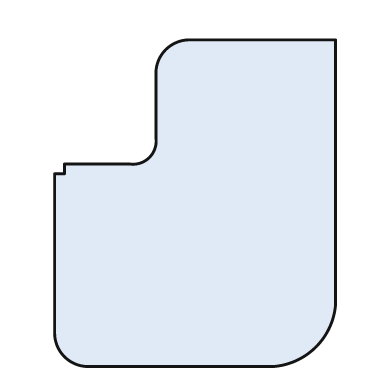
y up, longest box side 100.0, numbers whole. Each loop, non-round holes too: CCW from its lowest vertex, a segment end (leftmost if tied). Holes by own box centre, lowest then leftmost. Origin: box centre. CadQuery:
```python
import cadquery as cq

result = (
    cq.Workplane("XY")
    .moveTo(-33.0, -50.0)
    .lineTo(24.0, -50.0)
    .threePointArc((37.0, -44.0), (43.0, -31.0))
    .lineTo(43.0, 50.0)
    .lineTo(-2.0, 50.0)
    .threePointArc((-9.0, 47.0), (-12.0, 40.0))
    .lineTo(-12.0, 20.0)
    .threePointArc((-14.0, 14.0), (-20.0, 12.0))
    .lineTo(-40.0, 12.0)
    .lineTo(-40.0, 9.0)
    .lineTo(-43.0, 9.0)
    .lineTo(-43.0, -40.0)
    .threePointArc((-40.0, -47.0), (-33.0, -50.0))
    .close()
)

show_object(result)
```